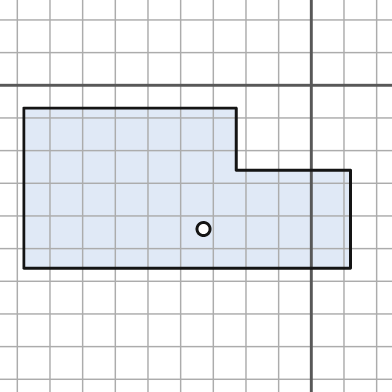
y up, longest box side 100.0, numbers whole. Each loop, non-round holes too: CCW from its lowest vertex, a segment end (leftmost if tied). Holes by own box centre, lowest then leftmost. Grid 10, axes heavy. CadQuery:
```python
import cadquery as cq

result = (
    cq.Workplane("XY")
    .moveTo(-88.0, -56.0)
    .lineTo(12.0, -56.0)
    .lineTo(12.0, -26.0)
    .lineTo(-23.0, -26.0)
    .lineTo(-23.0, -7.0)
    .lineTo(-88.0, -7.0)
    .close()
    .moveTo(-33.0, -44.0)
    .circle(2.0)
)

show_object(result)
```